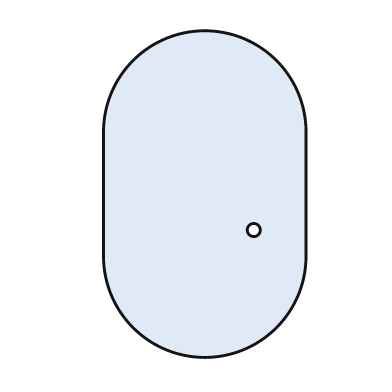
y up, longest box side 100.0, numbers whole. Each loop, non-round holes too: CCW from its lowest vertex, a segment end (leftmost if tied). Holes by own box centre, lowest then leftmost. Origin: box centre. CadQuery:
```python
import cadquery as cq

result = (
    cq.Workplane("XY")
    .moveTo(-31.0, -19.0)
    .threePointArc((0.0, -50.0), (31.0, -19.0))
    .lineTo(31.0, 19.0)
    .threePointArc((0.0, 50.0), (-31.0, 19.0))
    .close()
    .moveTo(15.0, -11.0)
    .circle(2.0)
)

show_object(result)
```